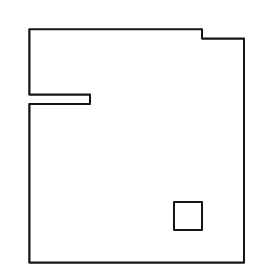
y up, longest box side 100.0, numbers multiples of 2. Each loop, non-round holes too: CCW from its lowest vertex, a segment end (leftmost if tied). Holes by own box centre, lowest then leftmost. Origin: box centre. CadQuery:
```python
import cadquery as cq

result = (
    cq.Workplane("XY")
    .moveTo(-46.0, -50.0)
    .lineTo(46.0, -50.0)
    .lineTo(46.0, 46.0)
    .lineTo(28.0, 46.0)
    .lineTo(28.0, 50.0)
    .lineTo(-46.0, 50.0)
    .lineTo(-46.0, 22.0)
    .lineTo(-20.0, 22.0)
    .lineTo(-20.0, 18.0)
    .lineTo(-46.0, 18.0)
    .close()
    .moveTo(16.0, -36.0)
    .lineTo(28.0, -36.0)
    .lineTo(28.0, -24.0)
    .lineTo(16.0, -24.0)
    .close()
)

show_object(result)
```